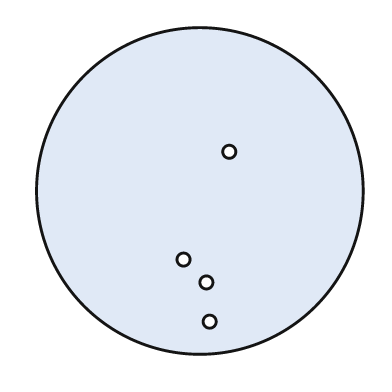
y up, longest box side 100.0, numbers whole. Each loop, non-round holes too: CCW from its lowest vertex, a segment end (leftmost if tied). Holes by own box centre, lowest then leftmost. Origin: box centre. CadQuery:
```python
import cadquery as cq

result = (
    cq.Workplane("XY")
    .moveTo(0.0, 0.0)
    .circle(50.0)
    .moveTo(3.0, -40.0)
    .circle(2.0)
    .moveTo(2.0, -28.0)
    .circle(2.0)
    .moveTo(-5.0, -21.0)
    .circle(2.0)
    .moveTo(9.0, 12.0)
    .circle(2.0)
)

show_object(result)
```